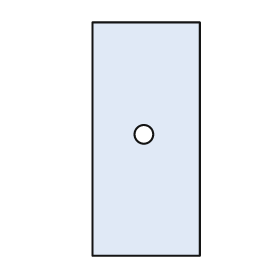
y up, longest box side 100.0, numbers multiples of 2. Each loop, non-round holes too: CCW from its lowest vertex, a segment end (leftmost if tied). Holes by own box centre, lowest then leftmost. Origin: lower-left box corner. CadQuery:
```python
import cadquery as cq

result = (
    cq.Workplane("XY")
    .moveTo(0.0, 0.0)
    .lineTo(46.0, 0.0)
    .lineTo(46.0, 100.0)
    .lineTo(0.0, 100.0)
    .close()
    .moveTo(22.0, 52.0)
    .circle(4.0)
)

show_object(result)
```